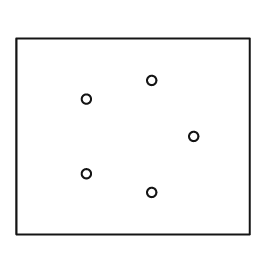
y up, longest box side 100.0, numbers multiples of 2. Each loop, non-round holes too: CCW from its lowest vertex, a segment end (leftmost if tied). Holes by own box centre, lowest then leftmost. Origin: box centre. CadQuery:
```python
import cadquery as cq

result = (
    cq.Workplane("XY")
    .moveTo(-50.0, -42.0)
    .lineTo(50.0, -42.0)
    .lineTo(50.0, 42.0)
    .lineTo(-50.0, 42.0)
    .close()
    .moveTo(8.0, -24.0)
    .circle(2.0)
    .moveTo(-20.0, -16.0)
    .circle(2.0)
    .moveTo(26.0, 0.0)
    .circle(2.0)
    .moveTo(-20.0, 16.0)
    .circle(2.0)
    .moveTo(8.0, 24.0)
    .circle(2.0)
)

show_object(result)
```